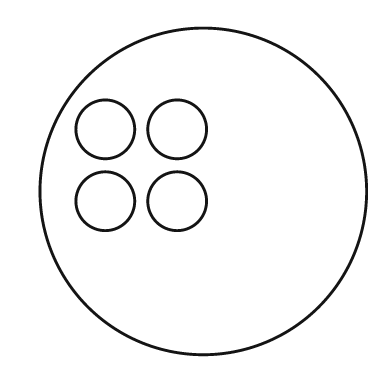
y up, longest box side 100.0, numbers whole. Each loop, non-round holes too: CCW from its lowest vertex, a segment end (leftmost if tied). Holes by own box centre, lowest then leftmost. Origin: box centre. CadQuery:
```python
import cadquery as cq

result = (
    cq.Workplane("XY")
    .moveTo(0.0, 0.0)
    .circle(50.0)
    .moveTo(-30.0, -3.0)
    .circle(9.0)
    .moveTo(-8.0, -3.0)
    .circle(9.0)
    .moveTo(-30.0, 19.0)
    .circle(9.0)
    .moveTo(-8.0, 19.0)
    .circle(9.0)
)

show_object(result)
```